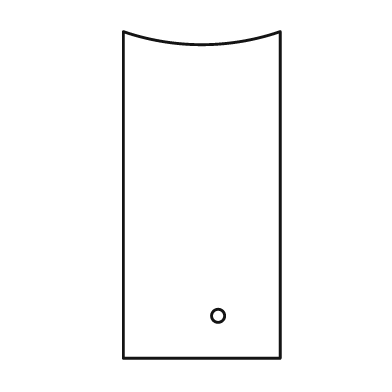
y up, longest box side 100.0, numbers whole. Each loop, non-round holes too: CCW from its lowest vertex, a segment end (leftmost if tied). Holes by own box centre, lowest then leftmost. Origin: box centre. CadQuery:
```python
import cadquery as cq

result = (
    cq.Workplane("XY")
    .moveTo(-24.0, -50.0)
    .lineTo(24.0, -50.0)
    .lineTo(24.0, 50.0)
    .threePointArc((0.0, 46.0), (-24.0, 50.0))
    .close()
    .moveTo(5.0, -37.0)
    .circle(2.0)
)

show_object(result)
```